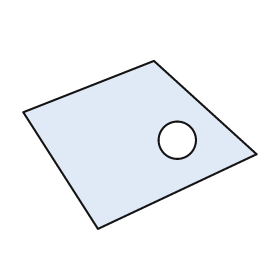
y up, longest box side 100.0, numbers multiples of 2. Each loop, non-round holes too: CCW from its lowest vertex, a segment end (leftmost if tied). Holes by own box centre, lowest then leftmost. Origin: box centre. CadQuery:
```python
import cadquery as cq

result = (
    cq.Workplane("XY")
    .moveTo(-18.0, -36.0)
    .lineTo(50.0, -4.0)
    .lineTo(6.0, 36.0)
    .lineTo(-50.0, 14.0)
    .close()
    .moveTo(16.0, 2.0)
    .circle(8.0)
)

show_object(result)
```